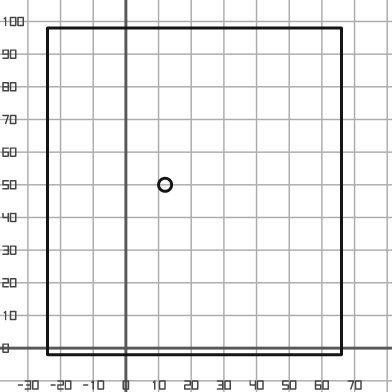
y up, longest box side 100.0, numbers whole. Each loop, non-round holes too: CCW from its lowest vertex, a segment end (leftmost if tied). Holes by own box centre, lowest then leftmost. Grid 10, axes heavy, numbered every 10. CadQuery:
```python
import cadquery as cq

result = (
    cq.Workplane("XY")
    .moveTo(-24.0, -2.0)
    .lineTo(66.0, -2.0)
    .lineTo(66.0, 98.0)
    .lineTo(-24.0, 98.0)
    .close()
    .moveTo(12.0, 50.0)
    .circle(2.0)
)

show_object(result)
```